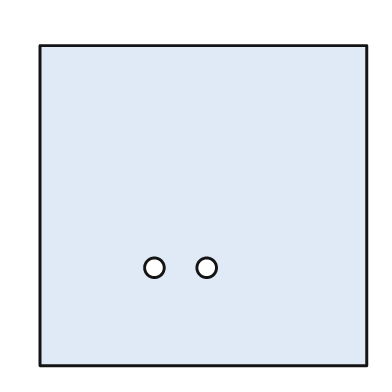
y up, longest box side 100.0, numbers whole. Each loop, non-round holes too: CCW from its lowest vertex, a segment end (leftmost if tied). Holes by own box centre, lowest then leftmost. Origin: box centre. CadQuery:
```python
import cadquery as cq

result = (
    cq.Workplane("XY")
    .moveTo(-50.0, -49.0)
    .lineTo(50.0, -49.0)
    .lineTo(50.0, 49.0)
    .lineTo(-50.0, 49.0)
    .close()
    .moveTo(-15.0, -19.0)
    .circle(3.0)
    .moveTo(1.0, -19.0)
    .circle(3.0)
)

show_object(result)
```